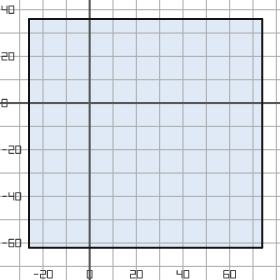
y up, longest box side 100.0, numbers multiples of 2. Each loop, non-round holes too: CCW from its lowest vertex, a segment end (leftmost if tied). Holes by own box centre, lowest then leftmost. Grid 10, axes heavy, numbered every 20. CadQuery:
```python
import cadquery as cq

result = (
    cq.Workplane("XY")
    .moveTo(-26.0, -62.0)
    .lineTo(74.0, -62.0)
    .lineTo(74.0, 36.0)
    .lineTo(-26.0, 36.0)
    .close()
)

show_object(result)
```